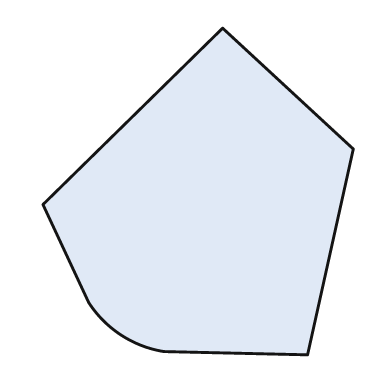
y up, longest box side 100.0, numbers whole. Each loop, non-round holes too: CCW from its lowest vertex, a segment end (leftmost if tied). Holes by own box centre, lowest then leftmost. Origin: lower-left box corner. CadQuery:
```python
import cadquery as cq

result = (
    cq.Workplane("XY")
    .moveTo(81.0, 0.0)
    .lineTo(95.0, 63.0)
    .lineTo(55.0, 100.0)
    .lineTo(0.0, 46.0)
    .lineTo(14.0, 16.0)
    .threePointArc((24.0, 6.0), (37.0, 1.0))
    .close()
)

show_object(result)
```